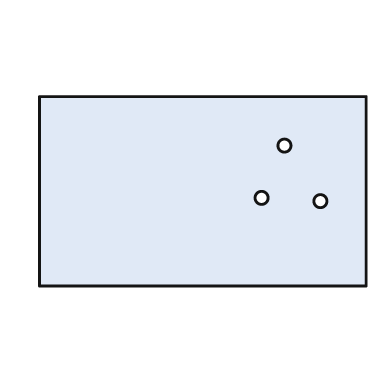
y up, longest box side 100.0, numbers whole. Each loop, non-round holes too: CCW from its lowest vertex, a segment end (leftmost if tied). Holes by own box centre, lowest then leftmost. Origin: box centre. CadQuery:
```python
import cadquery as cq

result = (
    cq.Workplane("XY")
    .moveTo(-50.0, -29.0)
    .lineTo(50.0, -29.0)
    .lineTo(50.0, 29.0)
    .lineTo(-50.0, 29.0)
    .close()
    .moveTo(36.0, -3.0)
    .circle(2.0)
    .moveTo(18.0, -2.0)
    .circle(2.0)
    .moveTo(25.0, 14.0)
    .circle(2.0)
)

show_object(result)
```